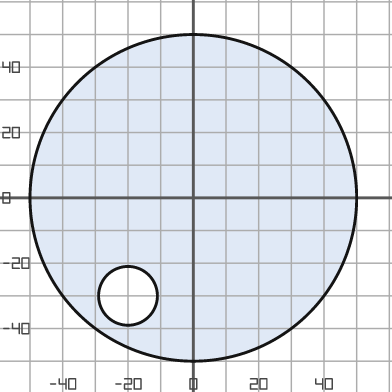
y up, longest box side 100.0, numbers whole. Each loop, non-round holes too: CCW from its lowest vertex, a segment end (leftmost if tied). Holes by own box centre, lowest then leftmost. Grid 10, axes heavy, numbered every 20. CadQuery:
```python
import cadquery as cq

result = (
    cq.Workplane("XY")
    .moveTo(0.0, 0.0)
    .circle(50.0)
    .moveTo(-20.0, -30.0)
    .circle(9.0)
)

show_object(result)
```